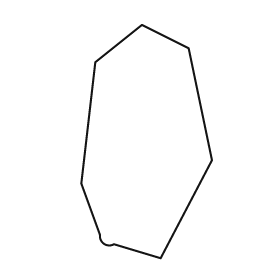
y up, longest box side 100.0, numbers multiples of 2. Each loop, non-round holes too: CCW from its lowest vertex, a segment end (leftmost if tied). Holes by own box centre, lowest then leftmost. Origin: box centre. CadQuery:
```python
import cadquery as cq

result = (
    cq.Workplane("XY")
    .moveTo(6.0, -50.0)
    .lineTo(28.0, -8.0)
    .lineTo(18.0, 40.0)
    .lineTo(-2.0, 50.0)
    .lineTo(-22.0, 34.0)
    .lineTo(-28.0, -18.0)
    .lineTo(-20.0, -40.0)
    .threePointArc((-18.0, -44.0), (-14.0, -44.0))
    .close()
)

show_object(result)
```